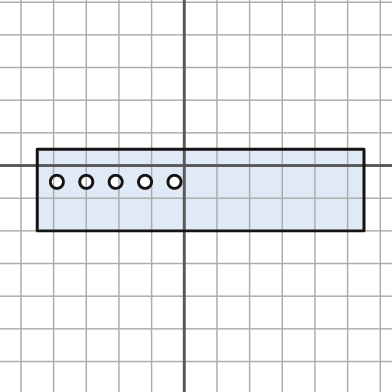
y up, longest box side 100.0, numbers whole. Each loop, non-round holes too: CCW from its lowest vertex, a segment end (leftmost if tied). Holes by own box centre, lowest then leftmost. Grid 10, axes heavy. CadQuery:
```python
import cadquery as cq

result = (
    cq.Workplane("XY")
    .moveTo(-45.0, -20.0)
    .lineTo(55.0, -20.0)
    .lineTo(55.0, 5.0)
    .lineTo(-45.0, 5.0)
    .close()
    .moveTo(-39.0, -5.0)
    .circle(2.0)
    .moveTo(-30.0, -5.0)
    .circle(2.0)
    .moveTo(-21.0, -5.0)
    .circle(2.0)
    .moveTo(-12.0, -5.0)
    .circle(2.0)
    .moveTo(-3.0, -5.0)
    .circle(2.0)
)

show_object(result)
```